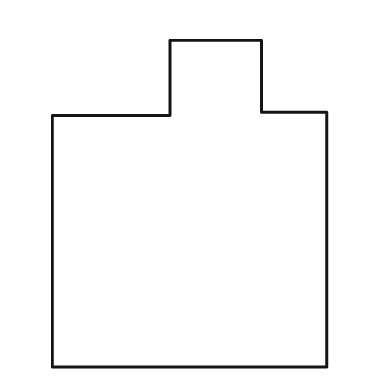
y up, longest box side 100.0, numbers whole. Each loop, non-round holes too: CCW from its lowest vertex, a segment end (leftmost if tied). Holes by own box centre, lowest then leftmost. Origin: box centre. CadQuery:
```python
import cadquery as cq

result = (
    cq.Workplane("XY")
    .moveTo(-42.0, -50.0)
    .lineTo(42.0, -50.0)
    .lineTo(42.0, 28.0)
    .lineTo(22.0, 28.0)
    .lineTo(22.0, 50.0)
    .lineTo(-6.0, 50.0)
    .lineTo(-6.0, 27.0)
    .lineTo(-42.0, 27.0)
    .close()
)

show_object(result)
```